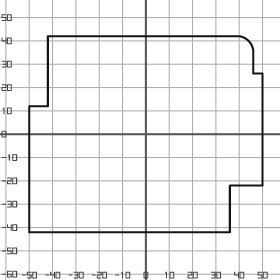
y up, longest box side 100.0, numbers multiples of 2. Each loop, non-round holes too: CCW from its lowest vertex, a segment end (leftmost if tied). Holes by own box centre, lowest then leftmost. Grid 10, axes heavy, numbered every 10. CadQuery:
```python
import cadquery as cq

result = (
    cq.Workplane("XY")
    .moveTo(-50.0, -42.0)
    .lineTo(36.0, -42.0)
    .lineTo(36.0, -22.0)
    .lineTo(50.0, -22.0)
    .lineTo(50.0, 26.0)
    .lineTo(46.0, 26.0)
    .lineTo(46.0, 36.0)
    .threePointArc((44.0, 40.0), (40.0, 42.0))
    .lineTo(-42.0, 42.0)
    .lineTo(-42.0, 12.0)
    .lineTo(-50.0, 12.0)
    .close()
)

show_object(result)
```